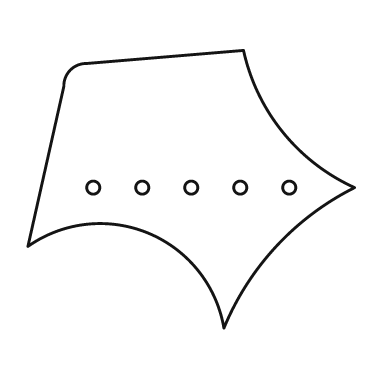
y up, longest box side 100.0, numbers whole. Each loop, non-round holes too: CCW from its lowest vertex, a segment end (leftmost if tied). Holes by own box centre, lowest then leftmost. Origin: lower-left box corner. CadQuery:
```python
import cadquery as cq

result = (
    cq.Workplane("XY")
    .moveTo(60.0, 0.0)
    .threePointArc((76.0, 25.0), (100.0, 43.0))
    .threePointArc((78.0, 60.0), (66.0, 85.0))
    .lineTo(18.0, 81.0)
    .threePointArc((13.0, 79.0), (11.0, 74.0))
    .lineTo(0.0, 25.0)
    .threePointArc((37.0, 29.0), (60.0, 0.0))
    .close()
    .moveTo(20.0, 43.0)
    .circle(2.0)
    .moveTo(35.0, 43.0)
    .circle(2.0)
    .moveTo(50.0, 43.0)
    .circle(2.0)
    .moveTo(65.0, 43.0)
    .circle(2.0)
    .moveTo(80.0, 43.0)
    .circle(2.0)
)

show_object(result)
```